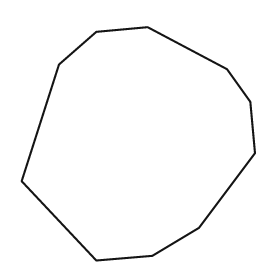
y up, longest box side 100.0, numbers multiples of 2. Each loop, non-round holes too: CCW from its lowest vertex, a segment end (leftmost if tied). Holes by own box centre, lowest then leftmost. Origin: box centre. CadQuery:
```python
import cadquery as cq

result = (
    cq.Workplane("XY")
    .moveTo(-18.0, -50.0)
    .lineTo(6.0, -48.0)
    .lineTo(26.0, -36.0)
    .lineTo(50.0, -4.0)
    .lineTo(48.0, 18.0)
    .lineTo(38.0, 32.0)
    .lineTo(4.0, 50.0)
    .lineTo(-18.0, 48.0)
    .lineTo(-34.0, 34.0)
    .lineTo(-50.0, -16.0)
    .close()
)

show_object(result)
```